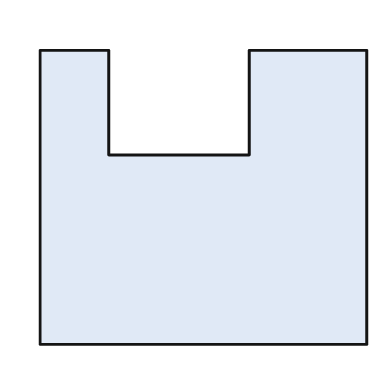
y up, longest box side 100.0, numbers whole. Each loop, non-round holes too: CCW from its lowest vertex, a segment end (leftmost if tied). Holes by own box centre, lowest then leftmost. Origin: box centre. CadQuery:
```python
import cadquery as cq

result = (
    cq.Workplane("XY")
    .moveTo(-50.0, -45.0)
    .lineTo(50.0, -45.0)
    .lineTo(50.0, 45.0)
    .lineTo(14.0, 45.0)
    .lineTo(14.0, 13.0)
    .lineTo(-29.0, 13.0)
    .lineTo(-29.0, 45.0)
    .lineTo(-50.0, 45.0)
    .close()
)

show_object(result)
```